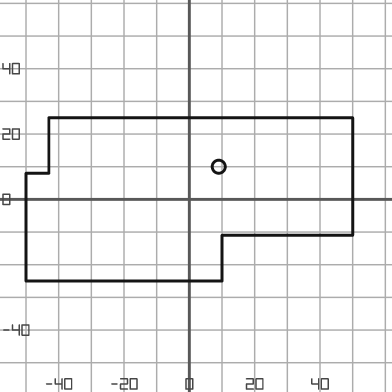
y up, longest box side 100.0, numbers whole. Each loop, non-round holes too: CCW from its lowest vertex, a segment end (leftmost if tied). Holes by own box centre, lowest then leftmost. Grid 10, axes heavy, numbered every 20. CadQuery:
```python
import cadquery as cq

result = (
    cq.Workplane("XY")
    .moveTo(-50.0, -25.0)
    .lineTo(10.0, -25.0)
    .lineTo(10.0, -11.0)
    .lineTo(50.0, -11.0)
    .lineTo(50.0, 25.0)
    .lineTo(-43.0, 25.0)
    .lineTo(-43.0, 8.0)
    .lineTo(-50.0, 8.0)
    .close()
    .moveTo(9.0, 10.0)
    .circle(2.0)
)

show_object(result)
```